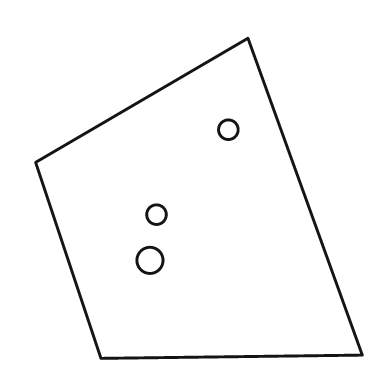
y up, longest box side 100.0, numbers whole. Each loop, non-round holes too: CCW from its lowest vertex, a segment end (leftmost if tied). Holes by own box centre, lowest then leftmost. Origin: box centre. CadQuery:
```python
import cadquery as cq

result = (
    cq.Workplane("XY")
    .moveTo(-30.0, -49.0)
    .lineTo(50.0, -48.0)
    .lineTo(15.0, 49.0)
    .lineTo(-50.0, 11.0)
    .close()
    .moveTo(-15.0, -19.0)
    .circle(4.0)
    .moveTo(-13.0, -5.0)
    .circle(3.0)
    .moveTo(9.0, 21.0)
    .circle(3.0)
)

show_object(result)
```